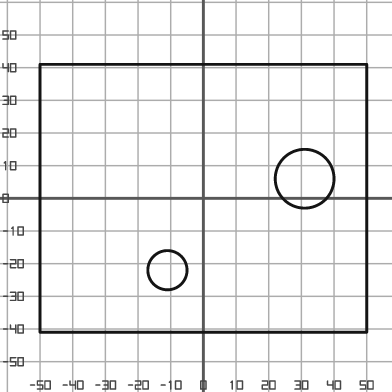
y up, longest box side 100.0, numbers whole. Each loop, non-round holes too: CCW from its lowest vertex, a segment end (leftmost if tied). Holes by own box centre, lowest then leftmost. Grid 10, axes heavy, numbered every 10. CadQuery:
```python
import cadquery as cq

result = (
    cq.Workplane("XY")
    .moveTo(-50.0, -41.0)
    .lineTo(50.0, -41.0)
    .lineTo(50.0, 41.0)
    .lineTo(-50.0, 41.0)
    .close()
    .moveTo(-11.0, -22.0)
    .circle(6.0)
    .moveTo(31.0, 6.0)
    .circle(9.0)
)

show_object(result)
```